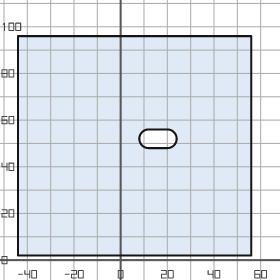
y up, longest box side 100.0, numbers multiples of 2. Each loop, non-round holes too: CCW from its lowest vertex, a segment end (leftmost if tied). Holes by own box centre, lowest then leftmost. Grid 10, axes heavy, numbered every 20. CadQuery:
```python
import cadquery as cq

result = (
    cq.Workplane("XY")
    .moveTo(-44.0, 2.0)
    .lineTo(56.0, 2.0)
    .lineTo(56.0, 96.0)
    .lineTo(-44.0, 96.0)
    .close()
    .moveTo(12.0, 48.0)
    .lineTo(20.0, 48.0)
    .threePointArc((24.0, 52.0), (20.0, 56.0))
    .lineTo(12.0, 56.0)
    .threePointArc((8.0, 52.0), (12.0, 48.0))
    .close()
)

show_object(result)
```